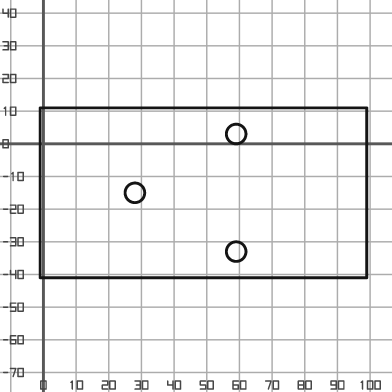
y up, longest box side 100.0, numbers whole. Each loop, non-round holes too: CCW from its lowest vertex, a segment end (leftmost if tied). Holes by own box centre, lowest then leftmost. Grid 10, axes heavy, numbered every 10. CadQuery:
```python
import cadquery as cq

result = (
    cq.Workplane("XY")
    .moveTo(-1.0, -41.0)
    .lineTo(99.0, -41.0)
    .lineTo(99.0, 11.0)
    .lineTo(-1.0, 11.0)
    .close()
    .moveTo(59.0, -33.0)
    .circle(3.0)
    .moveTo(28.0, -15.0)
    .circle(3.0)
    .moveTo(59.0, 3.0)
    .circle(3.0)
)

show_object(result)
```